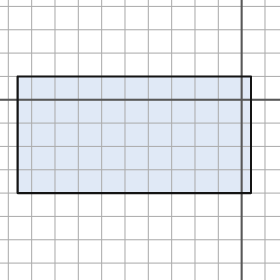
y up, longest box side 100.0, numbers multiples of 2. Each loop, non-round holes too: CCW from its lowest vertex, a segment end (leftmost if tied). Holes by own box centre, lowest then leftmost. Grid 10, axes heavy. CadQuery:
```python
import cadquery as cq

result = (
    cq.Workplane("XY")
    .moveTo(-96.0, -40.0)
    .lineTo(4.0, -40.0)
    .lineTo(4.0, 10.0)
    .lineTo(-96.0, 10.0)
    .close()
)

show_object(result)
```